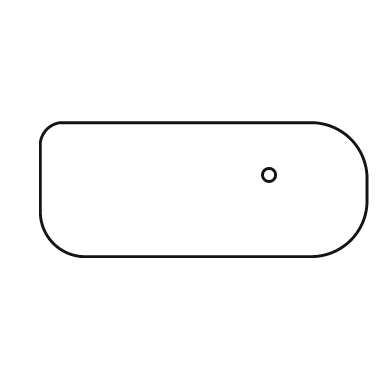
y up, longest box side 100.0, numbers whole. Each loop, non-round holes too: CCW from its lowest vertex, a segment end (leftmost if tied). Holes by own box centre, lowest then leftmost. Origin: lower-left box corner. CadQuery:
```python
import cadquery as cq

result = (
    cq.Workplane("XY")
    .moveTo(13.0, 0.0)
    .lineTo(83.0, 0.0)
    .threePointArc((95.0, 5.0), (100.0, 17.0))
    .lineTo(100.0, 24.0)
    .threePointArc((95.0, 36.0), (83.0, 41.0))
    .lineTo(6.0, 41.0)
    .threePointArc((2.0, 39.0), (0.0, 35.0))
    .lineTo(0.0, 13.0)
    .threePointArc((4.0, 4.0), (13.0, 0.0))
    .close()
    .moveTo(70.0, 25.0)
    .circle(2.0)
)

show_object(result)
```